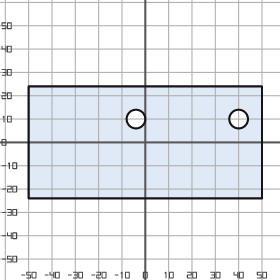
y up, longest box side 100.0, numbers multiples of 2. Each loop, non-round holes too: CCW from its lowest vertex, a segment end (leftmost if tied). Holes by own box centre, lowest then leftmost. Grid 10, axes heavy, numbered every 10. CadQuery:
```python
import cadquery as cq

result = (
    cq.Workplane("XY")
    .moveTo(-50.0, -24.0)
    .lineTo(50.0, -24.0)
    .lineTo(50.0, 24.0)
    .lineTo(-50.0, 24.0)
    .close()
    .moveTo(-4.0, 10.0)
    .circle(4.0)
    .moveTo(40.0, 10.0)
    .circle(4.0)
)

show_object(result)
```